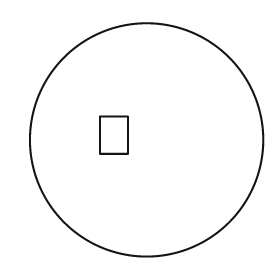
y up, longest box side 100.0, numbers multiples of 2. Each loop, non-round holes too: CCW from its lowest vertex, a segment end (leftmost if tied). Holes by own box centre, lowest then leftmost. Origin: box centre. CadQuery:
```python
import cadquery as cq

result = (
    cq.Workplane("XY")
    .moveTo(0.0, 0.0)
    .circle(50.0)
    .moveTo(-20.0, -6.0)
    .lineTo(-8.0, -6.0)
    .lineTo(-8.0, 10.0)
    .lineTo(-20.0, 10.0)
    .close()
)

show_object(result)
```